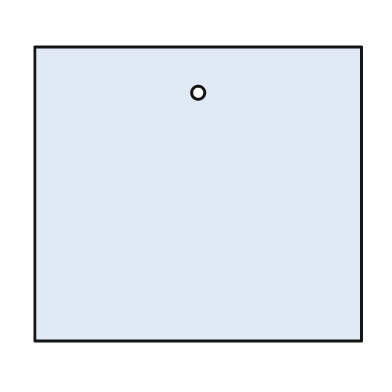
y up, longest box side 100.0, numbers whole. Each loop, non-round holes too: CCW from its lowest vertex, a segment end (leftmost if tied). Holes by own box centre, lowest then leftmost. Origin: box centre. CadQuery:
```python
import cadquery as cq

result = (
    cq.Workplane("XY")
    .moveTo(-50.0, -45.0)
    .lineTo(50.0, -45.0)
    .lineTo(50.0, 45.0)
    .lineTo(-50.0, 45.0)
    .close()
    .moveTo(0.0, 31.0)
    .circle(2.0)
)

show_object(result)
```